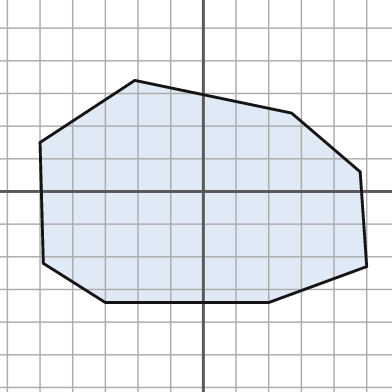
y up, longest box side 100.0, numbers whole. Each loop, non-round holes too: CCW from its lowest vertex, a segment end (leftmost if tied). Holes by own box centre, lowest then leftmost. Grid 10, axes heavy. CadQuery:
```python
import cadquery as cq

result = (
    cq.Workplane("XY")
    .moveTo(-30.0, -34.0)
    .lineTo(20.0, -34.0)
    .lineTo(50.0, -23.0)
    .lineTo(48.0, 6.0)
    .lineTo(27.0, 24.0)
    .lineTo(-21.0, 34.0)
    .lineTo(-50.0, 15.0)
    .lineTo(-49.0, -22.0)
    .close()
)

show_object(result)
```